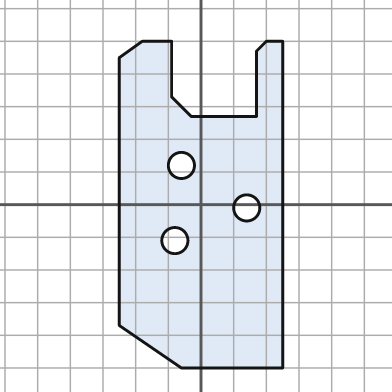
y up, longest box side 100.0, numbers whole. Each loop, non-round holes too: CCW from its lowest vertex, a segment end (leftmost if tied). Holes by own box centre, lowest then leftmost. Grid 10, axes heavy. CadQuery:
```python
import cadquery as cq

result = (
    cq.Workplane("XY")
    .moveTo(-6.0, -50.0)
    .lineTo(25.0, -50.0)
    .lineTo(25.0, 50.0)
    .lineTo(20.0, 50.0)
    .lineTo(17.0, 47.0)
    .lineTo(17.0, 27.0)
    .lineTo(-3.0, 27.0)
    .lineTo(-9.0, 33.0)
    .lineTo(-9.0, 50.0)
    .lineTo(-18.0, 50.0)
    .lineTo(-25.0, 45.0)
    .lineTo(-25.0, -37.0)
    .close()
    .moveTo(-8.0, -11.0)
    .circle(4.0)
    .moveTo(14.0, -1.0)
    .circle(4.0)
    .moveTo(-6.0, 12.0)
    .circle(4.0)
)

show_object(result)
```